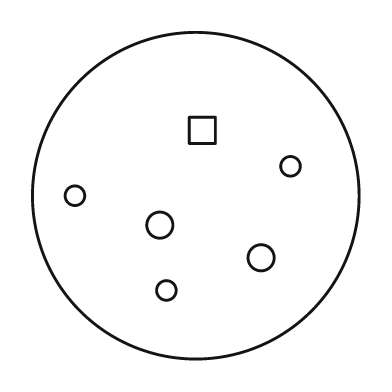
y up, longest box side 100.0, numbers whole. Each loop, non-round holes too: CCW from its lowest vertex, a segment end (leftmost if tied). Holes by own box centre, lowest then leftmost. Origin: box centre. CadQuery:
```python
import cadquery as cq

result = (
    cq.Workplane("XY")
    .moveTo(0.0, 0.0)
    .circle(50.0)
    .moveTo(-9.0, -29.0)
    .circle(3.0)
    .moveTo(20.0, -19.0)
    .circle(4.0)
    .moveTo(-11.0, -9.0)
    .circle(4.0)
    .moveTo(-37.0, 0.0)
    .circle(3.0)
    .moveTo(29.0, 9.0)
    .circle(3.0)
    .moveTo(-2.0, 16.0)
    .lineTo(6.0, 16.0)
    .lineTo(6.0, 24.0)
    .lineTo(-2.0, 24.0)
    .close()
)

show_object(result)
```